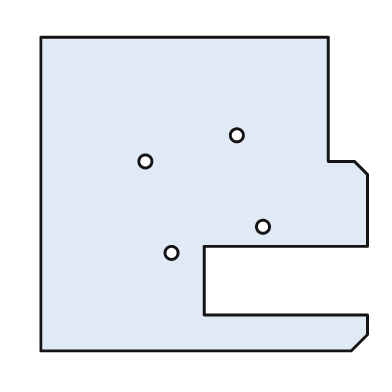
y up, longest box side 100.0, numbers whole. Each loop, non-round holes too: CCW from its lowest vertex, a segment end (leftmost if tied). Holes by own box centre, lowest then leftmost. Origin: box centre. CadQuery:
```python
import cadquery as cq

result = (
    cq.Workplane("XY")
    .moveTo(-50.0, -48.0)
    .lineTo(45.0, -48.0)
    .lineTo(50.0, -43.0)
    .lineTo(50.0, -37.0)
    .lineTo(0.0, -37.0)
    .lineTo(0.0, -16.0)
    .lineTo(50.0, -16.0)
    .lineTo(50.0, 6.0)
    .lineTo(46.0, 10.0)
    .lineTo(38.0, 10.0)
    .lineTo(38.0, 48.0)
    .lineTo(-50.0, 48.0)
    .close()
    .moveTo(-10.0, -18.0)
    .circle(2.0)
    .moveTo(18.0, -10.0)
    .circle(2.0)
    .moveTo(-18.0, 10.0)
    .circle(2.0)
    .moveTo(10.0, 18.0)
    .circle(2.0)
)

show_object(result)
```